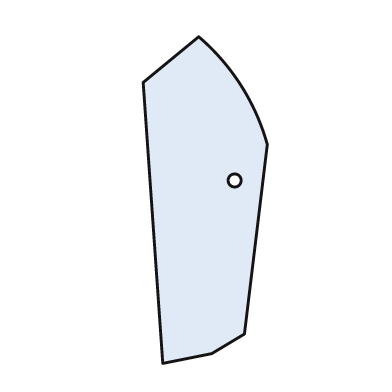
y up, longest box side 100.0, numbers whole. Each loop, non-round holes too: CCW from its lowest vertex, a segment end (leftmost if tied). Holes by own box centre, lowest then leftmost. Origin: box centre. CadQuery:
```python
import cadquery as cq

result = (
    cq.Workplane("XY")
    .moveTo(-13.0, -50.0)
    .lineTo(2.0, -47.0)
    .lineTo(12.0, -41.0)
    .lineTo(19.0, 17.0)
    .threePointArc((11.0, 35.0), (-2.0, 50.0))
    .lineTo(-19.0, 36.0)
    .close()
    .moveTo(9.0, 6.0)
    .circle(2.0)
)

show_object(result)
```